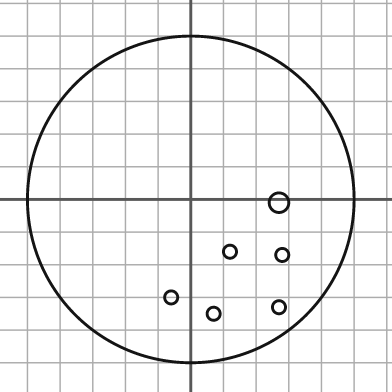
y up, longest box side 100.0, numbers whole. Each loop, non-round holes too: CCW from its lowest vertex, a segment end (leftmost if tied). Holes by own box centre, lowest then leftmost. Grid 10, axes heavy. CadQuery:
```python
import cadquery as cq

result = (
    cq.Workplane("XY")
    .moveTo(0.0, 0.0)
    .circle(50.0)
    .moveTo(7.0, -35.0)
    .circle(2.0)
    .moveTo(27.0, -33.0)
    .circle(2.0)
    .moveTo(-6.0, -30.0)
    .circle(2.0)
    .moveTo(28.0, -17.0)
    .circle(2.0)
    .moveTo(12.0, -16.0)
    .circle(2.0)
    .moveTo(27.0, -1.0)
    .circle(3.0)
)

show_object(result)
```